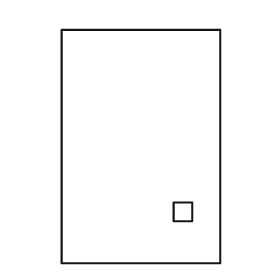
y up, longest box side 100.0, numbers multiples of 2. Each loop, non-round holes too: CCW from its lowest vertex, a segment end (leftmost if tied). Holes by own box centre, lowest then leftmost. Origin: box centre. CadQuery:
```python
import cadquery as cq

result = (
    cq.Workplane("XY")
    .moveTo(-34.0, -50.0)
    .lineTo(34.0, -50.0)
    .lineTo(34.0, 50.0)
    .lineTo(-34.0, 50.0)
    .close()
    .moveTo(14.0, -32.0)
    .lineTo(22.0, -32.0)
    .lineTo(22.0, -24.0)
    .lineTo(14.0, -24.0)
    .close()
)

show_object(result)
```